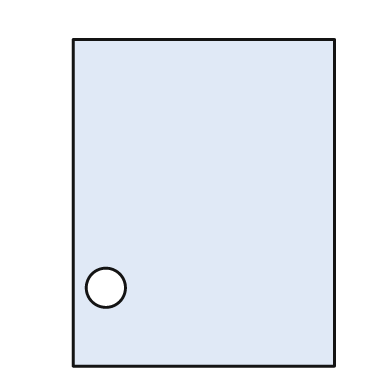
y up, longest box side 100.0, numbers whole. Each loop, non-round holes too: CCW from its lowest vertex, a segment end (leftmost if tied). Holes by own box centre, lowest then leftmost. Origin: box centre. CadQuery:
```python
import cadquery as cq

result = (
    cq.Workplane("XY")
    .moveTo(-40.0, -50.0)
    .lineTo(40.0, -50.0)
    .lineTo(40.0, 50.0)
    .lineTo(-40.0, 50.0)
    .close()
    .moveTo(-30.0, -26.0)
    .circle(6.0)
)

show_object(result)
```